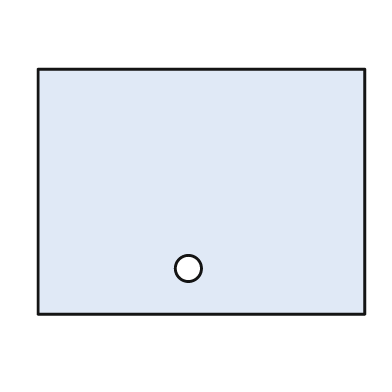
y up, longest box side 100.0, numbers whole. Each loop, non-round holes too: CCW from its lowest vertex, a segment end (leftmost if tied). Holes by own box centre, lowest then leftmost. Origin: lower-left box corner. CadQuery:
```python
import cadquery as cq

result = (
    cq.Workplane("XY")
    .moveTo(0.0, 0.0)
    .lineTo(100.0, 0.0)
    .lineTo(100.0, 75.0)
    .lineTo(0.0, 75.0)
    .close()
    .moveTo(46.0, 14.0)
    .circle(4.0)
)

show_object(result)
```